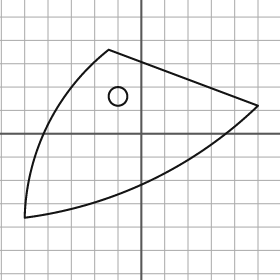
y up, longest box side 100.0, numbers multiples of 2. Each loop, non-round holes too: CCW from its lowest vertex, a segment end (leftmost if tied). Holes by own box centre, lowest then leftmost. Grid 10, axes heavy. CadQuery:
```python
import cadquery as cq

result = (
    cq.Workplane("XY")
    .moveTo(-50.0, -36.0)
    .threePointArc((4.0, -20.0), (50.0, 12.0))
    .lineTo(-14.0, 36.0)
    .threePointArc((-40.0, 4.0), (-50.0, -36.0))
    .close()
    .moveTo(-10.0, 16.0)
    .circle(4.0)
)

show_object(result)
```